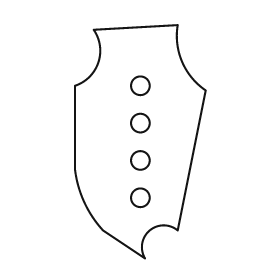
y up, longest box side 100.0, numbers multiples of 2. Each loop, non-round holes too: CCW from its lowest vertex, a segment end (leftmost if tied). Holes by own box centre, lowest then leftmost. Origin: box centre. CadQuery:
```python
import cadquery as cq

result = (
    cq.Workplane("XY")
    .moveTo(2.0, -50.0)
    .threePointArc((4.0, -38.0), (16.0, -38.0))
    .lineTo(28.0, 22.0)
    .threePointArc((18.0, 34.0), (16.0, 50.0))
    .lineTo(-20.0, 48.0)
    .threePointArc((-18.0, 34.0), (-28.0, 24.0))
    .lineTo(-28.0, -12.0)
    .threePointArc((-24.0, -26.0), (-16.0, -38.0))
    .close()
    .moveTo(0.0, -24.0)
    .circle(4.0)
    .moveTo(0.0, -8.0)
    .circle(4.0)
    .moveTo(0.0, 8.0)
    .circle(4.0)
    .moveTo(0.0, 24.0)
    .circle(4.0)
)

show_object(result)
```